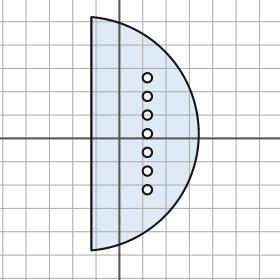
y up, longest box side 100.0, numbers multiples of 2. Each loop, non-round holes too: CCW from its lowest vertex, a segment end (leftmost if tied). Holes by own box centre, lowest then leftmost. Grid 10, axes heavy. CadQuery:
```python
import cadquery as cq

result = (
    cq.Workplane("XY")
    .moveTo(-12.0, -48.0)
    .threePointArc((34.0, 2.0), (-12.0, 52.0))
    .close()
    .moveTo(12.0, -22.0)
    .circle(2.0)
    .moveTo(12.0, -14.0)
    .circle(2.0)
    .moveTo(12.0, -6.0)
    .circle(2.0)
    .moveTo(12.0, 2.0)
    .circle(2.0)
    .moveTo(12.0, 10.0)
    .circle(2.0)
    .moveTo(12.0, 18.0)
    .circle(2.0)
    .moveTo(12.0, 26.0)
    .circle(2.0)
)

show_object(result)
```